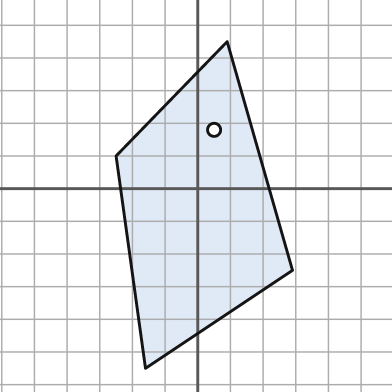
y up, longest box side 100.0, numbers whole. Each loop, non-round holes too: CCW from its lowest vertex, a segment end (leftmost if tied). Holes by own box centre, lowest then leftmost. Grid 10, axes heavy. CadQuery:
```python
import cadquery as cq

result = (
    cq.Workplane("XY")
    .moveTo(-16.0, -55.0)
    .lineTo(29.0, -25.0)
    .lineTo(9.0, 45.0)
    .lineTo(-25.0, 10.0)
    .close()
    .moveTo(5.0, 18.0)
    .circle(2.0)
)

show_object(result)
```